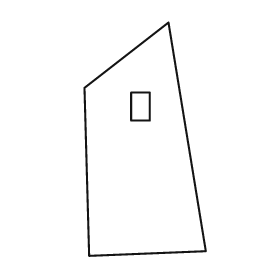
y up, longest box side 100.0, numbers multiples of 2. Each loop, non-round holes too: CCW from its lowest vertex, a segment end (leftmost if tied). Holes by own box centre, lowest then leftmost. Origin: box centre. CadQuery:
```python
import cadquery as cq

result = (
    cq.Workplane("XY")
    .moveTo(-24.0, -50.0)
    .lineTo(26.0, -48.0)
    .lineTo(10.0, 50.0)
    .lineTo(-26.0, 22.0)
    .close()
    .moveTo(-6.0, 8.0)
    .lineTo(2.0, 8.0)
    .lineTo(2.0, 20.0)
    .lineTo(-6.0, 20.0)
    .close()
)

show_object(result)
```